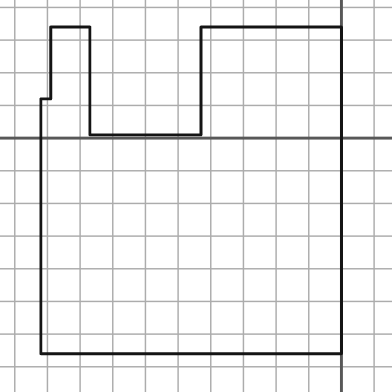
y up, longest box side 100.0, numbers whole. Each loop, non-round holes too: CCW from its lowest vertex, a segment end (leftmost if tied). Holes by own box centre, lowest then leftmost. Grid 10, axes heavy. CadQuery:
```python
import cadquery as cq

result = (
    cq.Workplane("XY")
    .moveTo(-92.0, -66.0)
    .lineTo(0.0, -66.0)
    .lineTo(0.0, 34.0)
    .lineTo(-43.0, 34.0)
    .lineTo(-43.0, 1.0)
    .lineTo(-77.0, 1.0)
    .lineTo(-77.0, 34.0)
    .lineTo(-89.0, 34.0)
    .lineTo(-89.0, 12.0)
    .lineTo(-92.0, 12.0)
    .close()
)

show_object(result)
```